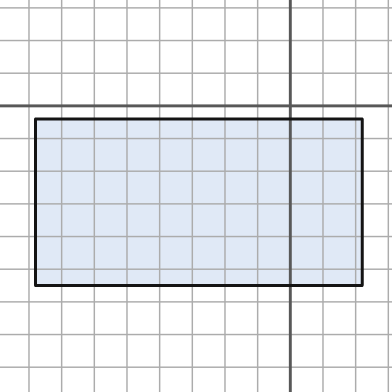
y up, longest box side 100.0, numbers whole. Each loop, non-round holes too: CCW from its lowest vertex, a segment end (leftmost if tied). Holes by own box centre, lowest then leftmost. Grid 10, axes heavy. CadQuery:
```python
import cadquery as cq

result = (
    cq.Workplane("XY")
    .moveTo(-78.0, -55.0)
    .lineTo(22.0, -55.0)
    .lineTo(22.0, -4.0)
    .lineTo(-78.0, -4.0)
    .close()
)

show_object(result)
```